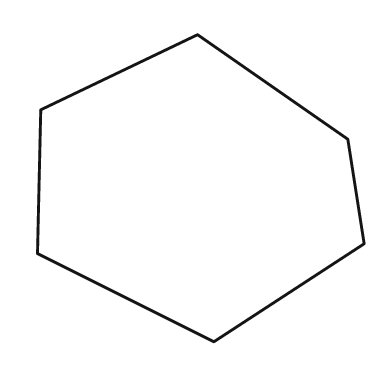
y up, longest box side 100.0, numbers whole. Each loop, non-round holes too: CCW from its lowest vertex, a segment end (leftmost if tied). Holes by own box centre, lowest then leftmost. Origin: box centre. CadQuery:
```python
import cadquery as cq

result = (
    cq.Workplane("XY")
    .moveTo(4.0, -47.0)
    .lineTo(50.0, -17.0)
    .lineTo(45.0, 15.0)
    .lineTo(-1.0, 47.0)
    .lineTo(-49.0, 24.0)
    .lineTo(-50.0, -20.0)
    .close()
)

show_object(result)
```